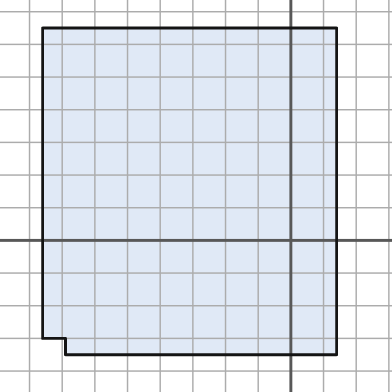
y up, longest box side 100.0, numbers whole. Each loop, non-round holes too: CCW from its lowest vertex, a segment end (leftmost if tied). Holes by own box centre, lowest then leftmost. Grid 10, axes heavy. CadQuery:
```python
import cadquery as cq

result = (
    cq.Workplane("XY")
    .moveTo(-69.0, -35.0)
    .lineTo(14.0, -35.0)
    .lineTo(14.0, 65.0)
    .lineTo(-76.0, 65.0)
    .lineTo(-76.0, -30.0)
    .lineTo(-69.0, -30.0)
    .close()
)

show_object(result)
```